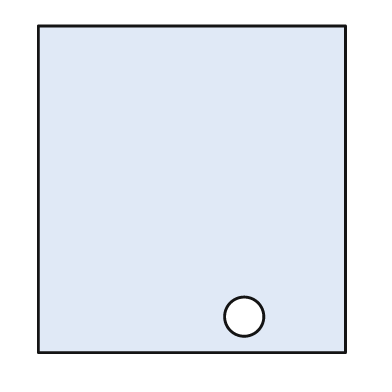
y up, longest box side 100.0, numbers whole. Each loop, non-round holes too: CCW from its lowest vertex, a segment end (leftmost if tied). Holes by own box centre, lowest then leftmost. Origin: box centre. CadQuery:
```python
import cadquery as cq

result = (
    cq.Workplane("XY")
    .moveTo(-47.0, -50.0)
    .lineTo(47.0, -50.0)
    .lineTo(47.0, 50.0)
    .lineTo(-47.0, 50.0)
    .close()
    .moveTo(16.0, -39.0)
    .circle(6.0)
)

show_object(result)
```